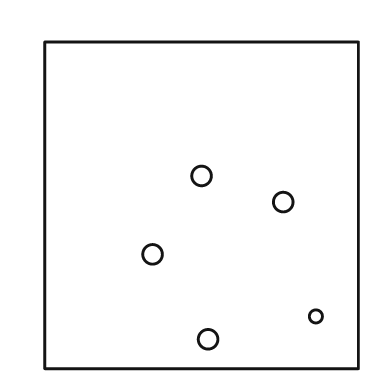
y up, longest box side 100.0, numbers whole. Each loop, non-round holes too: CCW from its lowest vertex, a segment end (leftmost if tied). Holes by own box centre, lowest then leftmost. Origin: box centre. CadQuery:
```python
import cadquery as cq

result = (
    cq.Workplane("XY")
    .moveTo(-48.0, -50.0)
    .lineTo(48.0, -50.0)
    .lineTo(48.0, 50.0)
    .lineTo(-48.0, 50.0)
    .close()
    .moveTo(2.0, -41.0)
    .circle(3.0)
    .moveTo(35.0, -34.0)
    .circle(2.0)
    .moveTo(-15.0, -15.0)
    .circle(3.0)
    .moveTo(25.0, 1.0)
    .circle(3.0)
    .moveTo(0.0, 9.0)
    .circle(3.0)
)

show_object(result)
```